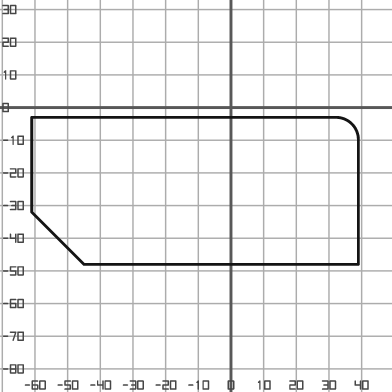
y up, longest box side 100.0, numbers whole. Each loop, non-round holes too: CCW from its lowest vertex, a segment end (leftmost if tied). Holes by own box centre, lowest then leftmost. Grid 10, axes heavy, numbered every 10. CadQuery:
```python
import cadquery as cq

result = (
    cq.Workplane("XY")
    .moveTo(-45.0, -48.0)
    .lineTo(39.0, -48.0)
    .lineTo(39.0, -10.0)
    .threePointArc((37.0, -5.0), (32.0, -3.0))
    .lineTo(-61.0, -3.0)
    .lineTo(-61.0, -32.0)
    .close()
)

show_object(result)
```